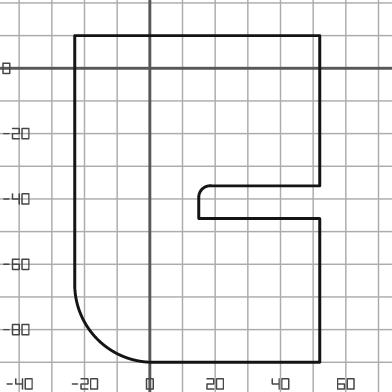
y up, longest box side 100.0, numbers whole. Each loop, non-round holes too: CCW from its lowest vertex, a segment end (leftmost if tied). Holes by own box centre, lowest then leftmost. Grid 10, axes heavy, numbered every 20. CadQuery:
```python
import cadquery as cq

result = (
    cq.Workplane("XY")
    .moveTo(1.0, -90.0)
    .lineTo(52.0, -90.0)
    .lineTo(52.0, -46.0)
    .lineTo(15.0, -46.0)
    .lineTo(15.0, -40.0)
    .threePointArc((16.0, -37.0), (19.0, -36.0))
    .lineTo(52.0, -36.0)
    .lineTo(52.0, 10.0)
    .lineTo(-23.0, 10.0)
    .lineTo(-23.0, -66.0)
    .threePointArc((-16.0, -83.0), (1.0, -90.0))
    .close()
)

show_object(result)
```